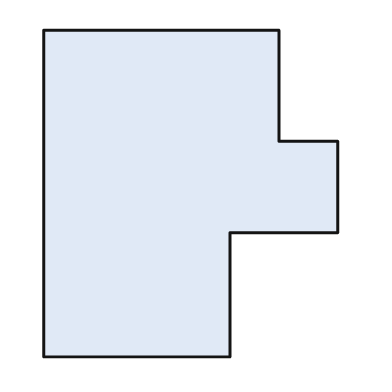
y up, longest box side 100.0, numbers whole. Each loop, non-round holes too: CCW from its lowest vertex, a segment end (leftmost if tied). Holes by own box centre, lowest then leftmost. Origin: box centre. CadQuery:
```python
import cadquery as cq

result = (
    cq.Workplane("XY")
    .moveTo(-45.0, -50.0)
    .lineTo(12.0, -50.0)
    .lineTo(12.0, -12.0)
    .lineTo(45.0, -12.0)
    .lineTo(45.0, 16.0)
    .lineTo(27.0, 16.0)
    .lineTo(27.0, 50.0)
    .lineTo(-45.0, 50.0)
    .close()
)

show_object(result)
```